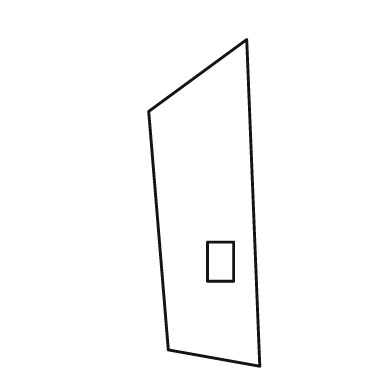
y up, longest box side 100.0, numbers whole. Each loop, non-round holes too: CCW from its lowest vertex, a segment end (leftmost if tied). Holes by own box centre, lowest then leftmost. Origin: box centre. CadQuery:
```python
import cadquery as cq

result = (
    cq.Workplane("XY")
    .moveTo(17.0, -50.0)
    .lineTo(13.0, 50.0)
    .lineTo(-17.0, 28.0)
    .lineTo(-11.0, -45.0)
    .close()
    .moveTo(1.0, -24.0)
    .lineTo(9.0, -24.0)
    .lineTo(9.0, -12.0)
    .lineTo(1.0, -12.0)
    .close()
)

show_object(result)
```